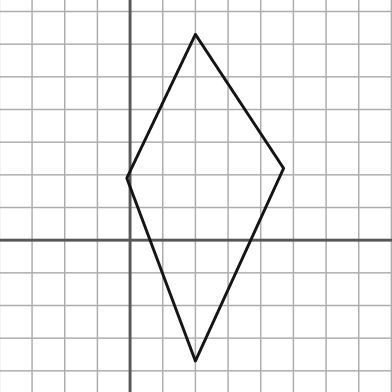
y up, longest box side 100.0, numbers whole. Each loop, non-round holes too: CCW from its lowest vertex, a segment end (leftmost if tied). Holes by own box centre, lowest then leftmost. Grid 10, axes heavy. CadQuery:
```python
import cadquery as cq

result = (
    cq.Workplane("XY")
    .moveTo(20.0, -37.0)
    .lineTo(47.0, 22.0)
    .lineTo(20.0, 63.0)
    .lineTo(-1.0, 19.0)
    .close()
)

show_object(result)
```